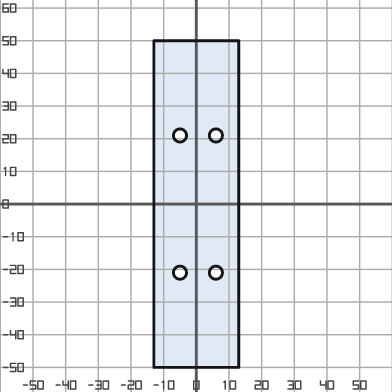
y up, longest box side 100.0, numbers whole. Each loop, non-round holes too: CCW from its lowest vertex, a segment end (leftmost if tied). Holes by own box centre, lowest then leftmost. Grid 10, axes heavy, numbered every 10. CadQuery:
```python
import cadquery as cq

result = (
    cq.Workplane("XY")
    .moveTo(-13.0, -50.0)
    .lineTo(13.0, -50.0)
    .lineTo(13.0, 50.0)
    .lineTo(-13.0, 50.0)
    .close()
    .moveTo(-5.0, -21.0)
    .circle(2.0)
    .moveTo(6.0, -21.0)
    .circle(2.0)
    .moveTo(-5.0, 21.0)
    .circle(2.0)
    .moveTo(6.0, 21.0)
    .circle(2.0)
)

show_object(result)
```